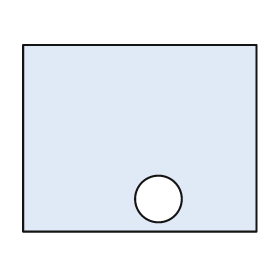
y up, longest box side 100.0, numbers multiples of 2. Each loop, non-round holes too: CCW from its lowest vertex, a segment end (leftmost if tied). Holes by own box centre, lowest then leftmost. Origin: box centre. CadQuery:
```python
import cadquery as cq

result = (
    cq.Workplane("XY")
    .moveTo(-50.0, -40.0)
    .lineTo(50.0, -40.0)
    .lineTo(50.0, 40.0)
    .lineTo(-50.0, 40.0)
    .close()
    .moveTo(8.0, -26.0)
    .circle(10.0)
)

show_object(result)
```